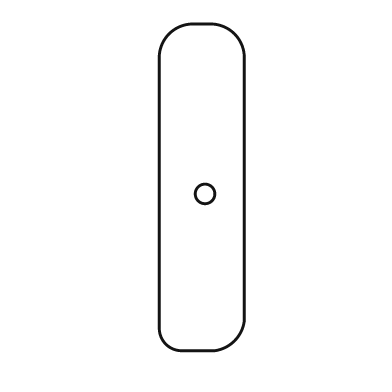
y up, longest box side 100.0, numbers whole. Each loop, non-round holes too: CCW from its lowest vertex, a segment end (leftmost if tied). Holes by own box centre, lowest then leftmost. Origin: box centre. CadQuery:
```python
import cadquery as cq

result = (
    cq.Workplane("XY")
    .moveTo(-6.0, -50.0)
    .lineTo(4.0, -50.0)
    .threePointArc((10.0, -47.0), (13.0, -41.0))
    .lineTo(13.0, 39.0)
    .threePointArc((10.0, 47.0), (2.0, 50.0))
    .lineTo(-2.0, 50.0)
    .threePointArc((-10.0, 47.0), (-13.0, 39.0))
    .lineTo(-13.0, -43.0)
    .threePointArc((-11.0, -48.0), (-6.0, -50.0))
    .close()
    .moveTo(1.0, -2.0)
    .circle(3.0)
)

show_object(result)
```